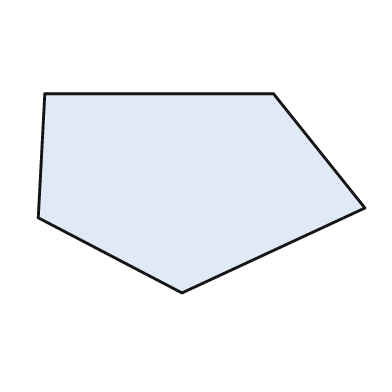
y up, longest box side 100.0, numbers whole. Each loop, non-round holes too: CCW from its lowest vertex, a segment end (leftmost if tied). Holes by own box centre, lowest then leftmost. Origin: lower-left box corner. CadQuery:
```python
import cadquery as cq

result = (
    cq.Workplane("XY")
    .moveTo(44.0, 0.0)
    .lineTo(100.0, 26.0)
    .lineTo(72.0, 61.0)
    .lineTo(2.0, 61.0)
    .lineTo(0.0, 23.0)
    .close()
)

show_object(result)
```